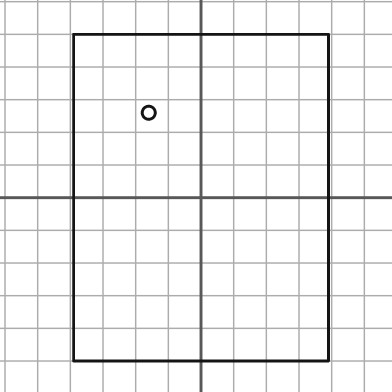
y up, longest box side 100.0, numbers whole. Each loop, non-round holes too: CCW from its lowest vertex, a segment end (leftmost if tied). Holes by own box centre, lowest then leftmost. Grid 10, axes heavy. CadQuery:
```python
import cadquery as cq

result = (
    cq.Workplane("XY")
    .moveTo(-39.0, -50.0)
    .lineTo(39.0, -50.0)
    .lineTo(39.0, 50.0)
    .lineTo(-39.0, 50.0)
    .close()
    .moveTo(-16.0, 26.0)
    .circle(2.0)
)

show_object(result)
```